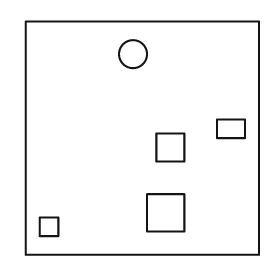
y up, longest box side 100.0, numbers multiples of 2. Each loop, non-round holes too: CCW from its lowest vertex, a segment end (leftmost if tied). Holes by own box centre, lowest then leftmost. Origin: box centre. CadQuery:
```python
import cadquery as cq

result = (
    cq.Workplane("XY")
    .moveTo(-50.0, -50.0)
    .lineTo(50.0, -50.0)
    .lineTo(50.0, 50.0)
    .lineTo(-50.0, 50.0)
    .close()
    .moveTo(-44.0, -42.0)
    .lineTo(-36.0, -42.0)
    .lineTo(-36.0, -34.0)
    .lineTo(-44.0, -34.0)
    .close()
    .moveTo(2.0, -40.0)
    .lineTo(18.0, -40.0)
    .lineTo(18.0, -24.0)
    .lineTo(2.0, -24.0)
    .close()
    .moveTo(6.0, -10.0)
    .lineTo(18.0, -10.0)
    .lineTo(18.0, 2.0)
    .lineTo(6.0, 2.0)
    .close()
    .moveTo(32.0, 0.0)
    .lineTo(44.0, 0.0)
    .lineTo(44.0, 8.0)
    .lineTo(32.0, 8.0)
    .close()
    .moveTo(-4.0, 36.0)
    .circle(6.0)
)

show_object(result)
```